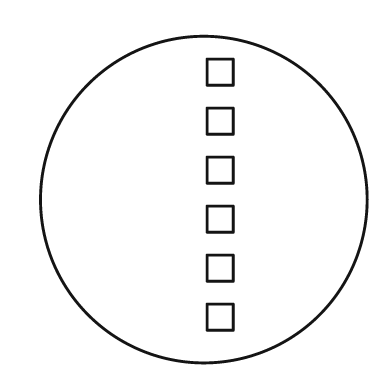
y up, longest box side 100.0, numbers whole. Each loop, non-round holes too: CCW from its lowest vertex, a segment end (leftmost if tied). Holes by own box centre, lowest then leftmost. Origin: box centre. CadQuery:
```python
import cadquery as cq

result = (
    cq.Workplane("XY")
    .moveTo(0.0, 0.0)
    .circle(50.0)
    .moveTo(1.0, -40.0)
    .lineTo(9.0, -40.0)
    .lineTo(9.0, -32.0)
    .lineTo(1.0, -32.0)
    .close()
    .moveTo(1.0, -25.0)
    .lineTo(9.0, -25.0)
    .lineTo(9.0, -17.0)
    .lineTo(1.0, -17.0)
    .close()
    .moveTo(1.0, -10.0)
    .lineTo(9.0, -10.0)
    .lineTo(9.0, -2.0)
    .lineTo(1.0, -2.0)
    .close()
    .moveTo(1.0, 5.0)
    .lineTo(9.0, 5.0)
    .lineTo(9.0, 13.0)
    .lineTo(1.0, 13.0)
    .close()
    .moveTo(1.0, 20.0)
    .lineTo(9.0, 20.0)
    .lineTo(9.0, 28.0)
    .lineTo(1.0, 28.0)
    .close()
    .moveTo(1.0, 35.0)
    .lineTo(9.0, 35.0)
    .lineTo(9.0, 43.0)
    .lineTo(1.0, 43.0)
    .close()
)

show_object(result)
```